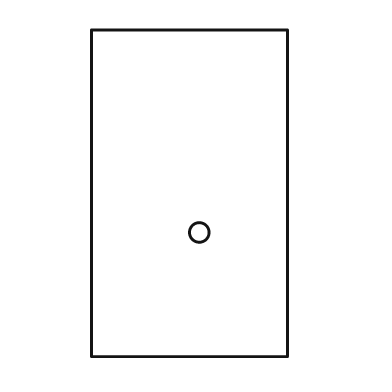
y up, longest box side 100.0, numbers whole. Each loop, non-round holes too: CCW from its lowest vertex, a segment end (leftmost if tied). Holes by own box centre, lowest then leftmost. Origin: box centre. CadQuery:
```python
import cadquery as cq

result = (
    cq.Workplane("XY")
    .moveTo(-30.0, -50.0)
    .lineTo(30.0, -50.0)
    .lineTo(30.0, 50.0)
    .lineTo(-30.0, 50.0)
    .close()
    .moveTo(3.0, -12.0)
    .circle(3.0)
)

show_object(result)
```